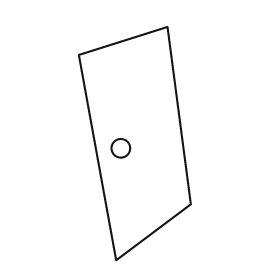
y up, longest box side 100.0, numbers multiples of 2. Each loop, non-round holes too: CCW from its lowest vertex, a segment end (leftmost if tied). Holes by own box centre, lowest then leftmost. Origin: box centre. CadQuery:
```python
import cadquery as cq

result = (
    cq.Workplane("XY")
    .moveTo(-8.0, -50.0)
    .lineTo(24.0, -26.0)
    .lineTo(14.0, 50.0)
    .lineTo(-24.0, 38.0)
    .close()
    .moveTo(-6.0, -2.0)
    .circle(4.0)
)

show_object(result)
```